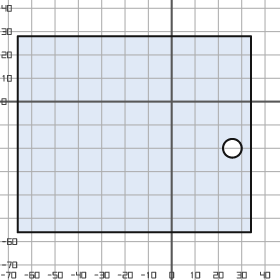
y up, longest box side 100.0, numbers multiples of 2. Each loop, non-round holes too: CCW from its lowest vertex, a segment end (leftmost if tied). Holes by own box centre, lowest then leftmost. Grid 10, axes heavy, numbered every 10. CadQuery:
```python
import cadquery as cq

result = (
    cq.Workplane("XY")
    .moveTo(-66.0, -56.0)
    .lineTo(34.0, -56.0)
    .lineTo(34.0, 28.0)
    .lineTo(-66.0, 28.0)
    .close()
    .moveTo(26.0, -20.0)
    .circle(4.0)
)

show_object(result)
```